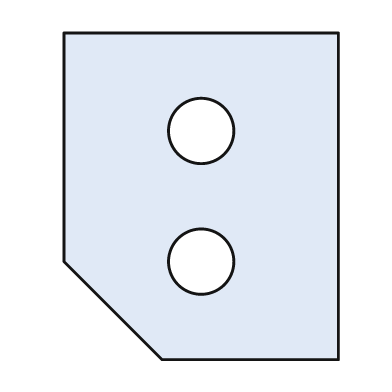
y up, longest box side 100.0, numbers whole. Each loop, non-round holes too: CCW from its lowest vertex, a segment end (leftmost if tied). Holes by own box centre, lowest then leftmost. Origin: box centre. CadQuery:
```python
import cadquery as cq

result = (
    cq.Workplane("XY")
    .moveTo(-12.0, -50.0)
    .lineTo(42.0, -50.0)
    .lineTo(42.0, 50.0)
    .lineTo(-42.0, 50.0)
    .lineTo(-42.0, -20.0)
    .close()
    .moveTo(0.0, -20.0)
    .circle(10.0)
    .moveTo(0.0, 20.0)
    .circle(10.0)
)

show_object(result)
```